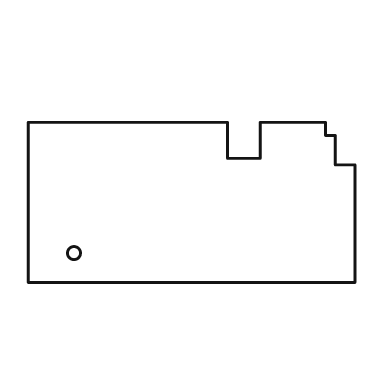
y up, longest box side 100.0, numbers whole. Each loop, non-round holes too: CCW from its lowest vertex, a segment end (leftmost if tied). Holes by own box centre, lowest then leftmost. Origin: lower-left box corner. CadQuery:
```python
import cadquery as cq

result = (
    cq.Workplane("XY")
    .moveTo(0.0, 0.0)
    .lineTo(100.0, 0.0)
    .lineTo(100.0, 36.0)
    .lineTo(94.0, 36.0)
    .lineTo(94.0, 45.0)
    .lineTo(91.0, 45.0)
    .lineTo(91.0, 49.0)
    .lineTo(71.0, 49.0)
    .lineTo(71.0, 38.0)
    .lineTo(61.0, 38.0)
    .lineTo(61.0, 49.0)
    .lineTo(0.0, 49.0)
    .close()
    .moveTo(14.0, 9.0)
    .circle(2.0)
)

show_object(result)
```